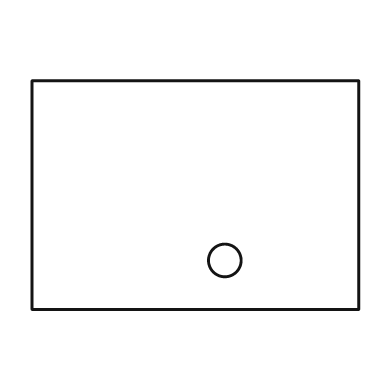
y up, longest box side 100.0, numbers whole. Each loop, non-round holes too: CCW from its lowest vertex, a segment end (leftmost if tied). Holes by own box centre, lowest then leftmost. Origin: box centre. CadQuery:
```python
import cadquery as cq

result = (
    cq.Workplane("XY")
    .moveTo(-50.0, -35.0)
    .lineTo(50.0, -35.0)
    .lineTo(50.0, 35.0)
    .lineTo(-50.0, 35.0)
    .close()
    .moveTo(9.0, -20.0)
    .circle(5.0)
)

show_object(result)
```